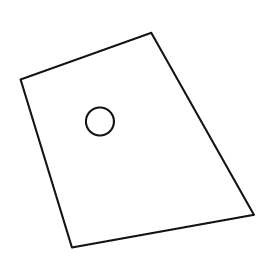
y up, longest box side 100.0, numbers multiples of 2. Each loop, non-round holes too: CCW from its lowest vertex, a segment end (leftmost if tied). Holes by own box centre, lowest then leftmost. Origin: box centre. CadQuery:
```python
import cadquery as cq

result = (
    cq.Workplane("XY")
    .moveTo(-28.0, -46.0)
    .lineTo(50.0, -32.0)
    .lineTo(6.0, 46.0)
    .lineTo(-50.0, 26.0)
    .close()
    .moveTo(-16.0, 8.0)
    .circle(6.0)
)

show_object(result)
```